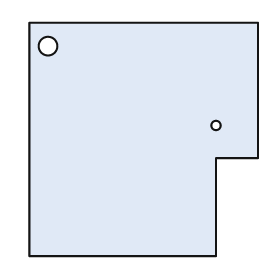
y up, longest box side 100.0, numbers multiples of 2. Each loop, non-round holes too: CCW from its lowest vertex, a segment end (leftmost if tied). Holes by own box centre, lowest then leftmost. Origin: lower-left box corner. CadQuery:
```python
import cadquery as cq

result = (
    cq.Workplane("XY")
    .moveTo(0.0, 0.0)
    .lineTo(80.0, 0.0)
    .lineTo(80.0, 42.0)
    .lineTo(98.0, 42.0)
    .lineTo(98.0, 100.0)
    .lineTo(0.0, 100.0)
    .close()
    .moveTo(80.0, 56.0)
    .circle(2.0)
    .moveTo(8.0, 90.0)
    .circle(4.0)
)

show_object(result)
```